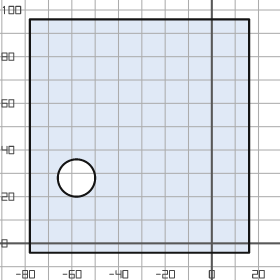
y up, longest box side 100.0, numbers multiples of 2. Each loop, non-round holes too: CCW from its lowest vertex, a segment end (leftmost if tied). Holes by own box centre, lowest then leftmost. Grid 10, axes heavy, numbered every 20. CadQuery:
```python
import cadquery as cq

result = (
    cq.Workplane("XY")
    .moveTo(-78.0, -4.0)
    .lineTo(16.0, -4.0)
    .lineTo(16.0, 96.0)
    .lineTo(-78.0, 96.0)
    .close()
    .moveTo(-58.0, 28.0)
    .circle(8.0)
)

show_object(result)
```